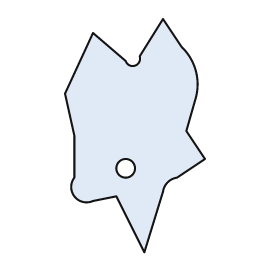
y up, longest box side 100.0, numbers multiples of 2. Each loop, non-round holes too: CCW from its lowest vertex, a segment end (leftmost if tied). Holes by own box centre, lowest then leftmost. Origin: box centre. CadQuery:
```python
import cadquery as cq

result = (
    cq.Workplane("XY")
    .moveTo(4.0, -50.0)
    .lineTo(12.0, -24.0)
    .threePointArc((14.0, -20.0), (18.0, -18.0))
    .lineTo(30.0, -10.0)
    .lineTo(22.0, 2.0)
    .lineTo(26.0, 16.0)
    .threePointArc((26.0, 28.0), (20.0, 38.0))
    .lineTo(12.0, 50.0)
    .lineTo(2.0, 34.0)
    .threePointArc((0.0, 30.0), (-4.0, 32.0))
    .lineTo(-18.0, 44.0)
    .lineTo(-30.0, 18.0)
    .lineTo(-26.0, 0.0)
    .lineTo(-26.0, -18.0)
    .threePointArc((-26.0, -26.0), (-18.0, -28.0))
    .lineTo(-8.0, -26.0)
    .close()
    .moveTo(-4.0, -14.0)
    .circle(4.0)
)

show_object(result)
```